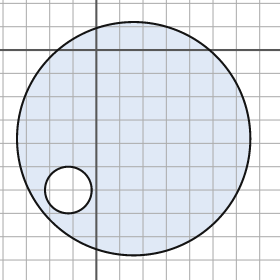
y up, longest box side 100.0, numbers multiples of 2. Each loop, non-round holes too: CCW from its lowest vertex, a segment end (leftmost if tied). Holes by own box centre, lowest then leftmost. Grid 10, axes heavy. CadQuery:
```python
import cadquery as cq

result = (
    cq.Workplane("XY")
    .moveTo(16.0, -38.0)
    .circle(50.0)
    .moveTo(-12.0, -60.0)
    .circle(10.0)
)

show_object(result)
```